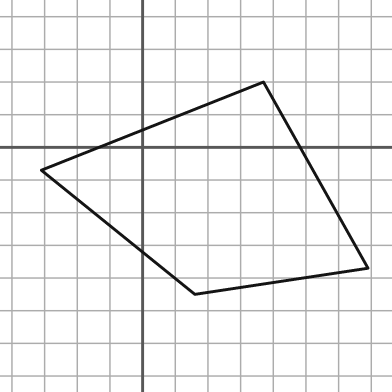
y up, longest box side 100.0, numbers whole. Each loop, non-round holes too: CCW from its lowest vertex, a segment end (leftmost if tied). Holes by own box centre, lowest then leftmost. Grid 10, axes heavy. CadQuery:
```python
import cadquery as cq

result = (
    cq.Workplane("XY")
    .moveTo(16.0, -45.0)
    .lineTo(69.0, -37.0)
    .lineTo(37.0, 20.0)
    .lineTo(-31.0, -7.0)
    .close()
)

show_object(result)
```